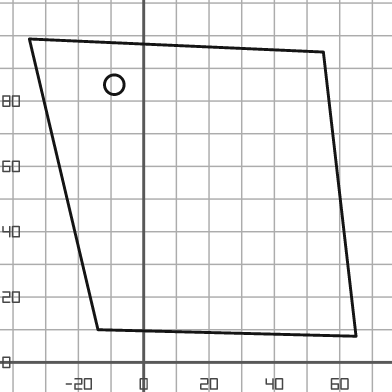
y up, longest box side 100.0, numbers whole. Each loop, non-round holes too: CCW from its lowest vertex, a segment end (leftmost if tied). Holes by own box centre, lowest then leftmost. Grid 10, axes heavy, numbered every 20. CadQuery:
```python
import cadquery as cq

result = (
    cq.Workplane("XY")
    .moveTo(65.0, 8.0)
    .lineTo(55.0, 95.0)
    .lineTo(-35.0, 99.0)
    .lineTo(-14.0, 10.0)
    .close()
    .moveTo(-9.0, 85.0)
    .circle(3.0)
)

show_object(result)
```